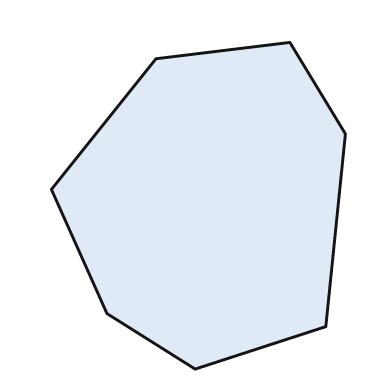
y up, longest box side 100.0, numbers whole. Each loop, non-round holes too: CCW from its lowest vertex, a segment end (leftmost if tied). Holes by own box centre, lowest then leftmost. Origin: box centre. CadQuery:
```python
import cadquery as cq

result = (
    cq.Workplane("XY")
    .moveTo(-1.0, -50.0)
    .lineTo(39.0, -37.0)
    .lineTo(45.0, 22.0)
    .lineTo(28.0, 50.0)
    .lineTo(-13.0, 45.0)
    .lineTo(-45.0, 5.0)
    .lineTo(-28.0, -33.0)
    .close()
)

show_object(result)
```